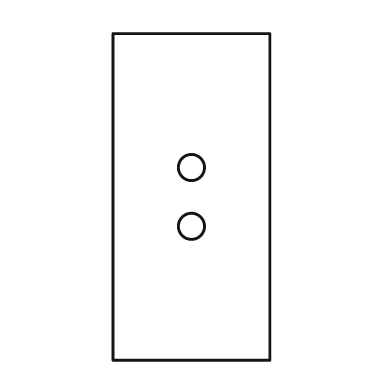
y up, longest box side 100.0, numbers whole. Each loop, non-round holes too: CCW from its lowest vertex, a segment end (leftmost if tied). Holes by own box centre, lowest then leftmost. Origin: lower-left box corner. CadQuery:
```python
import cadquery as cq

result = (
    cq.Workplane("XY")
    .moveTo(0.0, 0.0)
    .lineTo(48.0, 0.0)
    .lineTo(48.0, 100.0)
    .lineTo(0.0, 100.0)
    .close()
    .moveTo(24.0, 41.0)
    .circle(4.0)
    .moveTo(24.0, 59.0)
    .circle(4.0)
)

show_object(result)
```